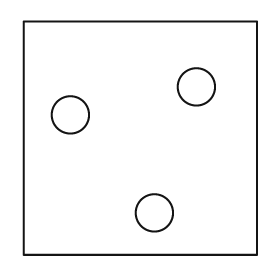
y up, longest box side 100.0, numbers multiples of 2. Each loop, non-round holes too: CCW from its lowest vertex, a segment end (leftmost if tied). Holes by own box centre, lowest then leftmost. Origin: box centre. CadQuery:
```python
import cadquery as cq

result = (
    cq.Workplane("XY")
    .moveTo(-50.0, -50.0)
    .lineTo(50.0, -50.0)
    .lineTo(50.0, 50.0)
    .lineTo(-50.0, 50.0)
    .close()
    .moveTo(6.0, -32.0)
    .circle(8.0)
    .moveTo(-30.0, 10.0)
    .circle(8.0)
    .moveTo(24.0, 22.0)
    .circle(8.0)
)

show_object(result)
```